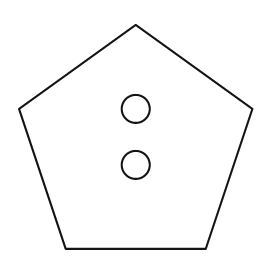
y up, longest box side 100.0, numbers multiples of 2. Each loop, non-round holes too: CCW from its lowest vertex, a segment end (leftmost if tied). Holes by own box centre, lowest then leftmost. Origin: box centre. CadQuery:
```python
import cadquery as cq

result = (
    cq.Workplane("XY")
    .moveTo(-30.0, -48.0)
    .lineTo(30.0, -48.0)
    .lineTo(50.0, 12.0)
    .lineTo(0.0, 48.0)
    .lineTo(-50.0, 12.0)
    .close()
    .moveTo(0.0, -12.0)
    .circle(6.0)
    .moveTo(0.0, 12.0)
    .circle(6.0)
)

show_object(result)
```